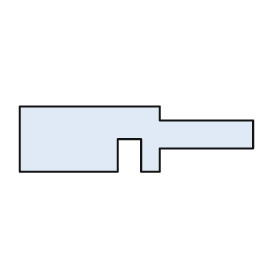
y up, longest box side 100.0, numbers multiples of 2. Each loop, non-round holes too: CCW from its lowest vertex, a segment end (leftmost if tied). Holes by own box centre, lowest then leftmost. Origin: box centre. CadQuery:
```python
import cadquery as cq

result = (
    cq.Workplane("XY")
    .moveTo(-50.0, -14.0)
    .lineTo(-8.0, -14.0)
    .lineTo(-8.0, 0.0)
    .lineTo(2.0, 0.0)
    .lineTo(2.0, -14.0)
    .lineTo(10.0, -14.0)
    .lineTo(10.0, -4.0)
    .lineTo(50.0, -4.0)
    .lineTo(50.0, 8.0)
    .lineTo(10.0, 8.0)
    .lineTo(10.0, 14.0)
    .lineTo(-50.0, 14.0)
    .close()
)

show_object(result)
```